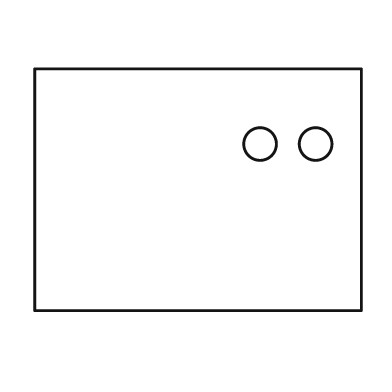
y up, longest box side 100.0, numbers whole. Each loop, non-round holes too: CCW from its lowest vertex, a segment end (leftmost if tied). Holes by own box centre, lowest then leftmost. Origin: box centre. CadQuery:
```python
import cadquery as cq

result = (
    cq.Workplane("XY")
    .moveTo(-50.0, -37.0)
    .lineTo(50.0, -37.0)
    .lineTo(50.0, 37.0)
    .lineTo(-50.0, 37.0)
    .close()
    .moveTo(19.0, 14.0)
    .circle(5.0)
    .moveTo(36.0, 14.0)
    .circle(5.0)
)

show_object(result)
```